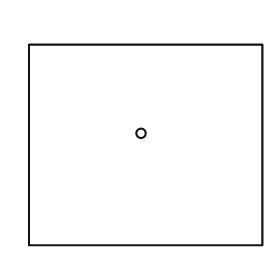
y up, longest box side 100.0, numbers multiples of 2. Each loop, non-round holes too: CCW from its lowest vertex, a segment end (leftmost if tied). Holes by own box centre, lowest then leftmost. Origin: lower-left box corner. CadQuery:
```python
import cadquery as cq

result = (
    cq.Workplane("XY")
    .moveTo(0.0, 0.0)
    .lineTo(100.0, 0.0)
    .lineTo(100.0, 86.0)
    .lineTo(0.0, 86.0)
    .close()
    .moveTo(48.0, 48.0)
    .circle(2.0)
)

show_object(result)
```